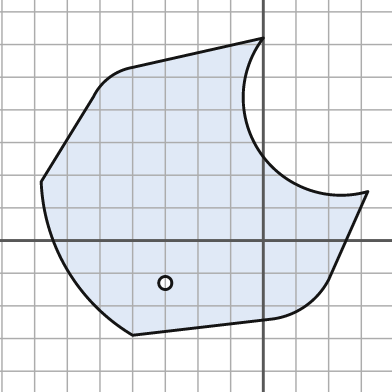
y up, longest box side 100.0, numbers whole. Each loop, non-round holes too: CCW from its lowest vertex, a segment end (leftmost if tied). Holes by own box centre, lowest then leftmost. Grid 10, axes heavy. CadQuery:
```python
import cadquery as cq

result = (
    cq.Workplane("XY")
    .moveTo(-40.0, -29.0)
    .lineTo(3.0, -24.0)
    .threePointArc((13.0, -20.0), (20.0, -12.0))
    .lineTo(32.0, 15.0)
    .threePointArc((-1.0, 27.0), (0.0, 62.0))
    .lineTo(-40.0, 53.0)
    .threePointArc((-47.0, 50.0), (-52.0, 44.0))
    .lineTo(-68.0, 18.0)
    .threePointArc((-60.0, -9.0), (-40.0, -29.0))
    .close()
    .moveTo(-30.0, -13.0)
    .circle(2.0)
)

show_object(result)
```